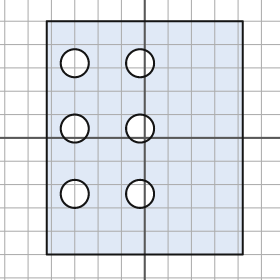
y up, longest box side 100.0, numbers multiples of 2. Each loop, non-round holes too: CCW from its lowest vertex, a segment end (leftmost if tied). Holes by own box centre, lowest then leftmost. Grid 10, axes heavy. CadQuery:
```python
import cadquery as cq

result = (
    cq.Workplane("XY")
    .moveTo(-42.0, -50.0)
    .lineTo(42.0, -50.0)
    .lineTo(42.0, 50.0)
    .lineTo(-42.0, 50.0)
    .close()
    .moveTo(-30.0, -24.0)
    .circle(6.0)
    .moveTo(-2.0, -24.0)
    .circle(6.0)
    .moveTo(-30.0, 4.0)
    .circle(6.0)
    .moveTo(-2.0, 4.0)
    .circle(6.0)
    .moveTo(-30.0, 32.0)
    .circle(6.0)
    .moveTo(-2.0, 32.0)
    .circle(6.0)
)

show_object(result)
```